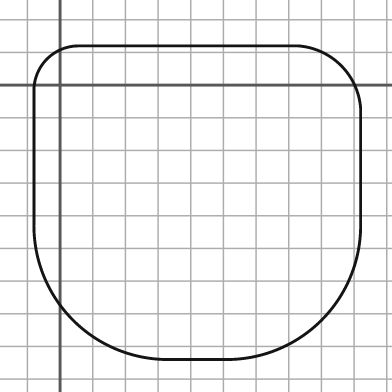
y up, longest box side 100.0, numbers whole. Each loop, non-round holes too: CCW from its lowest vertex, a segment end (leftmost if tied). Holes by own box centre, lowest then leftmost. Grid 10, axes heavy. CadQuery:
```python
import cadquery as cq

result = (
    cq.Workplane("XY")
    .moveTo(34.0, -84.0)
    .lineTo(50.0, -84.0)
    .threePointArc((80.0, -72.0), (92.0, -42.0))
    .lineTo(92.0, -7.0)
    .threePointArc((86.0, 6.0), (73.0, 12.0))
    .lineTo(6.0, 12.0)
    .threePointArc((-4.0, 8.0), (-8.0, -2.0))
    .lineTo(-8.0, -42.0)
    .threePointArc((4.0, -72.0), (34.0, -84.0))
    .close()
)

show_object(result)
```